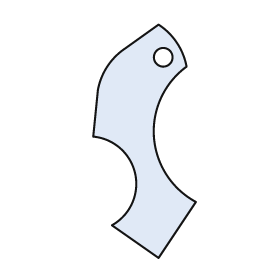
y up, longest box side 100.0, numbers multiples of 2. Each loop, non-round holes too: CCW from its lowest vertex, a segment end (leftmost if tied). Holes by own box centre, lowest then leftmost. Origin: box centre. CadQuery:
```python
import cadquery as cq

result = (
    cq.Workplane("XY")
    .moveTo(6.0, -50.0)
    .lineTo(22.0, -26.0)
    .threePointArc((4.0, 2.0), (18.0, 32.0))
    .threePointArc((14.0, 42.0), (6.0, 50.0))
    .lineTo(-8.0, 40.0)
    .threePointArc((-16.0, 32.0), (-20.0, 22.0))
    .lineTo(-22.0, 2.0)
    .threePointArc((-4.0, -14.0), (-14.0, -36.0))
    .close()
    .moveTo(8.0, 36.0)
    .circle(4.0)
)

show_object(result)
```